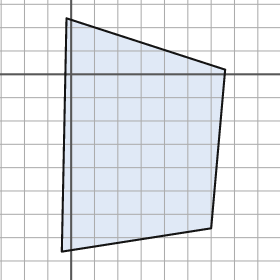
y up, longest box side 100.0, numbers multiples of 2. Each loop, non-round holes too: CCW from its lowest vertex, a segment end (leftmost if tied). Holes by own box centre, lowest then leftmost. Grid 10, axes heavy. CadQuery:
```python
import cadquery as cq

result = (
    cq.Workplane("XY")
    .moveTo(-4.0, -76.0)
    .lineTo(60.0, -66.0)
    .lineTo(66.0, 2.0)
    .lineTo(-2.0, 24.0)
    .close()
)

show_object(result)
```